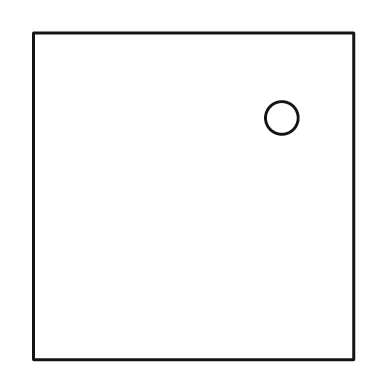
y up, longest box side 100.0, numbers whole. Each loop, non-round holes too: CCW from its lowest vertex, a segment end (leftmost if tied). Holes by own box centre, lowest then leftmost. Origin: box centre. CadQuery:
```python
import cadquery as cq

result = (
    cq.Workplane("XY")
    .moveTo(-49.0, -50.0)
    .lineTo(49.0, -50.0)
    .lineTo(49.0, 50.0)
    .lineTo(-49.0, 50.0)
    .close()
    .moveTo(27.0, 24.0)
    .circle(5.0)
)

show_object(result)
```